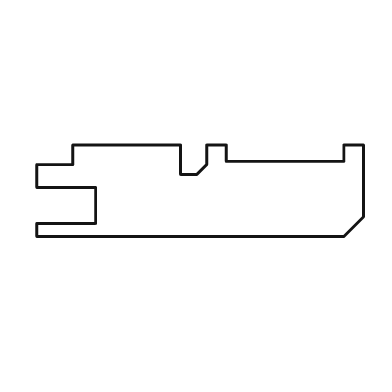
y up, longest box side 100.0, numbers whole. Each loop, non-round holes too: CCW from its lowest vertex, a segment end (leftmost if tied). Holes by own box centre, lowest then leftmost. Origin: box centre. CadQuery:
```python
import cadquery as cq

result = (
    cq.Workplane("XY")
    .moveTo(-50.0, -14.0)
    .lineTo(44.0, -14.0)
    .lineTo(50.0, -8.0)
    .lineTo(50.0, 14.0)
    .lineTo(44.0, 14.0)
    .lineTo(44.0, 9.0)
    .lineTo(8.0, 9.0)
    .lineTo(8.0, 14.0)
    .lineTo(2.0, 14.0)
    .lineTo(2.0, 8.0)
    .lineTo(-1.0, 5.0)
    .lineTo(-6.0, 5.0)
    .lineTo(-6.0, 14.0)
    .lineTo(-39.0, 14.0)
    .lineTo(-39.0, 8.0)
    .lineTo(-50.0, 8.0)
    .lineTo(-50.0, 1.0)
    .lineTo(-32.0, 1.0)
    .lineTo(-32.0, -10.0)
    .lineTo(-50.0, -10.0)
    .close()
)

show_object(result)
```